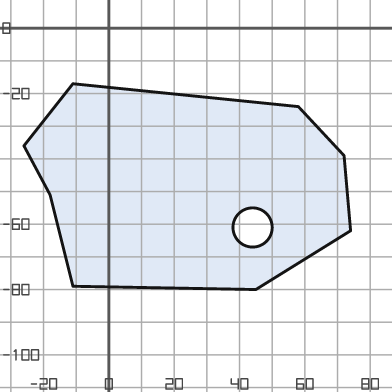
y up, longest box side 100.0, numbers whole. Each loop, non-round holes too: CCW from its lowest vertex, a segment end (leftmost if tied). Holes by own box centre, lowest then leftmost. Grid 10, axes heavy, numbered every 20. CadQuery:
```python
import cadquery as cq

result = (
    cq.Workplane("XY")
    .moveTo(45.0, -80.0)
    .lineTo(74.0, -62.0)
    .lineTo(72.0, -39.0)
    .lineTo(58.0, -24.0)
    .lineTo(-11.0, -17.0)
    .lineTo(-26.0, -36.0)
    .lineTo(-18.0, -51.0)
    .lineTo(-11.0, -79.0)
    .close()
    .moveTo(44.0, -61.0)
    .circle(6.0)
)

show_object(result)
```